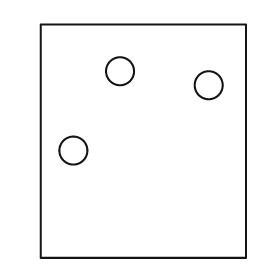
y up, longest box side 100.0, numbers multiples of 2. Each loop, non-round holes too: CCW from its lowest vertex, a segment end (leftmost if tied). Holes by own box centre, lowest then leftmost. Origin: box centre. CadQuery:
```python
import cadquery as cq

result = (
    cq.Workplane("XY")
    .moveTo(-44.0, -50.0)
    .lineTo(44.0, -50.0)
    .lineTo(44.0, 50.0)
    .lineTo(-44.0, 50.0)
    .close()
    .moveTo(-30.0, -4.0)
    .circle(6.0)
    .moveTo(28.0, 24.0)
    .circle(6.0)
    .moveTo(-10.0, 30.0)
    .circle(6.0)
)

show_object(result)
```